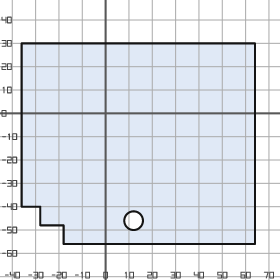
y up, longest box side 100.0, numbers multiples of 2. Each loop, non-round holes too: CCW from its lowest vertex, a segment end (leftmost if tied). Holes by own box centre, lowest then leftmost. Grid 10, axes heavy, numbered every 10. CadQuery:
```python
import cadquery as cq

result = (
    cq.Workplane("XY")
    .moveTo(-18.0, -56.0)
    .lineTo(64.0, -56.0)
    .lineTo(64.0, 30.0)
    .lineTo(-36.0, 30.0)
    .lineTo(-36.0, -40.0)
    .lineTo(-28.0, -40.0)
    .lineTo(-28.0, -48.0)
    .lineTo(-18.0, -48.0)
    .close()
    .moveTo(12.0, -46.0)
    .circle(4.0)
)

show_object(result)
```